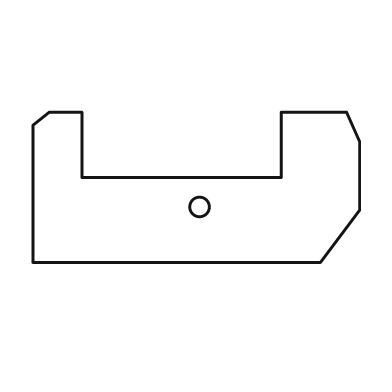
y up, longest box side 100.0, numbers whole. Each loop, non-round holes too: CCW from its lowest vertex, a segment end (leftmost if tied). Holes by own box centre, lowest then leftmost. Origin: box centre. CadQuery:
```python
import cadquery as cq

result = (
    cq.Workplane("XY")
    .moveTo(-50.0, -23.0)
    .lineTo(38.0, -23.0)
    .lineTo(50.0, -7.0)
    .lineTo(50.0, 14.0)
    .lineTo(46.0, 23.0)
    .lineTo(26.0, 23.0)
    .lineTo(26.0, 3.0)
    .lineTo(-35.0, 3.0)
    .lineTo(-35.0, 23.0)
    .lineTo(-45.0, 23.0)
    .lineTo(-50.0, 19.0)
    .close()
    .moveTo(1.0, -6.0)
    .circle(3.0)
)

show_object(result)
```